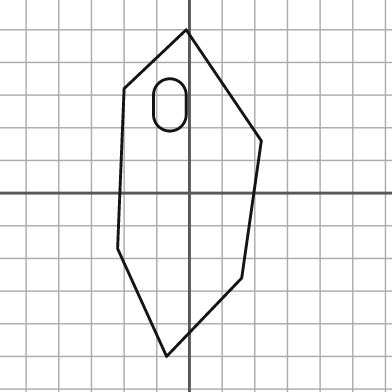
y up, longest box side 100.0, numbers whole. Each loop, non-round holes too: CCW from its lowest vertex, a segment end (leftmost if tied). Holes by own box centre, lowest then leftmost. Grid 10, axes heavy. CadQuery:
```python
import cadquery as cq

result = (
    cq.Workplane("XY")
    .moveTo(-7.0, -50.0)
    .lineTo(16.0, -26.0)
    .lineTo(22.0, 16.0)
    .lineTo(-1.0, 50.0)
    .lineTo(-20.0, 32.0)
    .lineTo(-22.0, -17.0)
    .close()
    .moveTo(-11.0, 24.0)
    .threePointArc((-6.0, 19.0), (-1.0, 24.0))
    .lineTo(-1.0, 30.0)
    .threePointArc((-6.0, 35.0), (-11.0, 30.0))
    .close()
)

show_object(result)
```